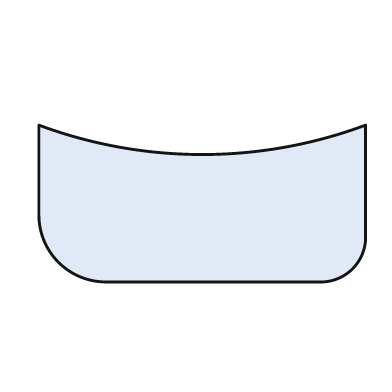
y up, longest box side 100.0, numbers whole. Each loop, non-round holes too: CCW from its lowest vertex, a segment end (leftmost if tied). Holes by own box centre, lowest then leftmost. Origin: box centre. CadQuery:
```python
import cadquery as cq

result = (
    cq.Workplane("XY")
    .moveTo(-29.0, -24.0)
    .lineTo(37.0, -24.0)
    .threePointArc((46.0, -20.0), (50.0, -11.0))
    .lineTo(50.0, 24.0)
    .threePointArc((0.0, 15.0), (-50.0, 24.0))
    .lineTo(-50.0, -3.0)
    .threePointArc((-44.0, -18.0), (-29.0, -24.0))
    .close()
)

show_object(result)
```